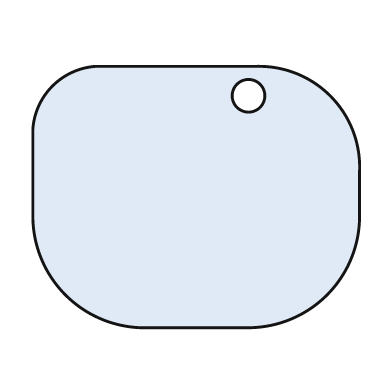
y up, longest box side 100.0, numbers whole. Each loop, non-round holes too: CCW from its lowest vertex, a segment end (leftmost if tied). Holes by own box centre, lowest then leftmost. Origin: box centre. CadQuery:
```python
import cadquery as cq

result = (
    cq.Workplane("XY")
    .moveTo(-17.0, -40.0)
    .lineTo(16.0, -40.0)
    .threePointArc((40.0, -30.0), (50.0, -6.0))
    .lineTo(50.0, 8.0)
    .threePointArc((41.0, 31.0), (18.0, 40.0))
    .lineTo(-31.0, 40.0)
    .threePointArc((-44.0, 34.0), (-50.0, 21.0))
    .lineTo(-50.0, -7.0)
    .threePointArc((-40.0, -30.0), (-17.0, -40.0))
    .close()
    .moveTo(16.0, 31.0)
    .circle(5.0)
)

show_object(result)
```